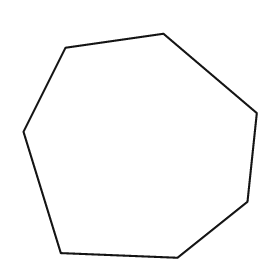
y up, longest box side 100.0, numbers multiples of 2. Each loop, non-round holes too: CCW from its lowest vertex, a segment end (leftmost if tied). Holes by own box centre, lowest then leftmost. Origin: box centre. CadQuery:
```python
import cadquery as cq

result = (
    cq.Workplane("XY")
    .moveTo(16.0, -48.0)
    .lineTo(46.0, -24.0)
    .lineTo(50.0, 14.0)
    .lineTo(10.0, 48.0)
    .lineTo(-32.0, 42.0)
    .lineTo(-50.0, 6.0)
    .lineTo(-34.0, -46.0)
    .close()
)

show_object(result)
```